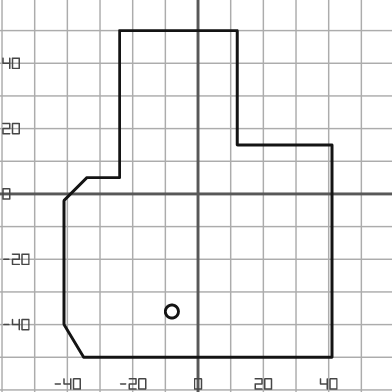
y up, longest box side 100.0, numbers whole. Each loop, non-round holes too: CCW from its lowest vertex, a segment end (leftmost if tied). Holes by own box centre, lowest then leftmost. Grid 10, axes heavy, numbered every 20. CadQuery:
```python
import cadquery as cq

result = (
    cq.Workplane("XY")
    .moveTo(-35.0, -50.0)
    .lineTo(41.0, -50.0)
    .lineTo(41.0, 15.0)
    .lineTo(12.0, 15.0)
    .lineTo(12.0, 50.0)
    .lineTo(-24.0, 50.0)
    .lineTo(-24.0, 5.0)
    .lineTo(-34.0, 5.0)
    .lineTo(-41.0, -2.0)
    .lineTo(-41.0, -40.0)
    .close()
    .moveTo(-8.0, -36.0)
    .circle(2.0)
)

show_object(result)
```